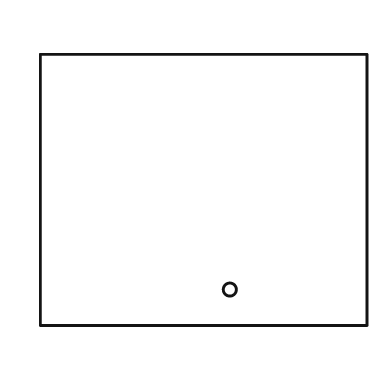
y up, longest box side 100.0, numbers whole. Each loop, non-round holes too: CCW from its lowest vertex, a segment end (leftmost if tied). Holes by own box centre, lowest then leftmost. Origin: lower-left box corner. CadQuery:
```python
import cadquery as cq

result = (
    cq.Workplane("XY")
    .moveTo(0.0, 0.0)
    .lineTo(100.0, 0.0)
    .lineTo(100.0, 83.0)
    .lineTo(0.0, 83.0)
    .close()
    .moveTo(58.0, 11.0)
    .circle(2.0)
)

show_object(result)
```